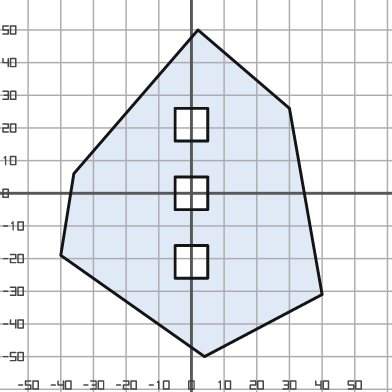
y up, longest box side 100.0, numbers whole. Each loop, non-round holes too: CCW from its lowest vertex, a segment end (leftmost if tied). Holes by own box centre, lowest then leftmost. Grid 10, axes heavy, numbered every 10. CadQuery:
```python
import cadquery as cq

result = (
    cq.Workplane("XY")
    .moveTo(4.0, -50.0)
    .lineTo(40.0, -31.0)
    .lineTo(30.0, 26.0)
    .lineTo(2.0, 50.0)
    .lineTo(-36.0, 6.0)
    .lineTo(-40.0, -19.0)
    .close()
    .moveTo(-5.0, -26.0)
    .lineTo(5.0, -26.0)
    .lineTo(5.0, -16.0)
    .lineTo(-5.0, -16.0)
    .close()
    .moveTo(-5.0, -5.0)
    .lineTo(5.0, -5.0)
    .lineTo(5.0, 5.0)
    .lineTo(-5.0, 5.0)
    .close()
    .moveTo(-5.0, 16.0)
    .lineTo(5.0, 16.0)
    .lineTo(5.0, 26.0)
    .lineTo(-5.0, 26.0)
    .close()
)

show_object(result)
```